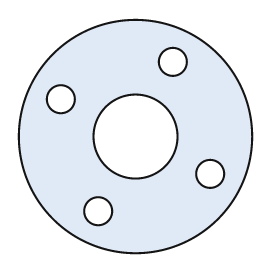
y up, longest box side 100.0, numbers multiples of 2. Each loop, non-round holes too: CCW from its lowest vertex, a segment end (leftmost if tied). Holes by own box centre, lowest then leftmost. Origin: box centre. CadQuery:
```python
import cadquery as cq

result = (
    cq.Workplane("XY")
    .moveTo(0.0, 0.0)
    .circle(50.0)
    .moveTo(-16.0, -32.0)
    .circle(6.0)
    .moveTo(32.0, -16.0)
    .circle(6.0)
    .moveTo(0.0, 0.0)
    .circle(18.0)
    .moveTo(-32.0, 16.0)
    .circle(6.0)
    .moveTo(16.0, 32.0)
    .circle(6.0)
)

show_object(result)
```